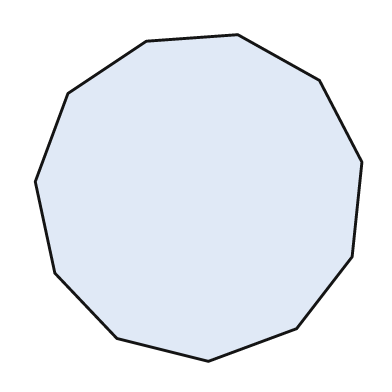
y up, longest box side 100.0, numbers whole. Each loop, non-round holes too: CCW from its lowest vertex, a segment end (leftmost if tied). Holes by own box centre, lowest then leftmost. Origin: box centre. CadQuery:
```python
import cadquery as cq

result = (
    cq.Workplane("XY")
    .moveTo(3.0, -50.0)
    .lineTo(30.0, -40.0)
    .lineTo(47.0, -18.0)
    .lineTo(50.0, 11.0)
    .lineTo(37.0, 36.0)
    .lineTo(12.0, 50.0)
    .lineTo(-16.0, 48.0)
    .lineTo(-40.0, 32.0)
    .lineTo(-50.0, 5.0)
    .lineTo(-44.0, -23.0)
    .lineTo(-25.0, -43.0)
    .close()
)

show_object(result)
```